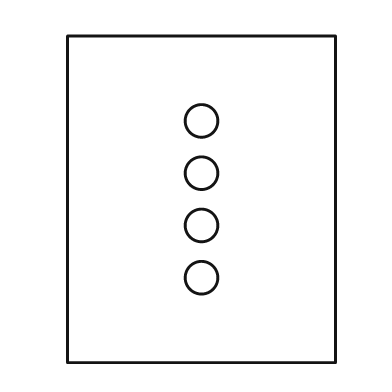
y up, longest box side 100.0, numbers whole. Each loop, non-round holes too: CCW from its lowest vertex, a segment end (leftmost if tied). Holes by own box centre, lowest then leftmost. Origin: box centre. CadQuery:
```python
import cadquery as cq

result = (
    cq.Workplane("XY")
    .moveTo(-41.0, -50.0)
    .lineTo(41.0, -50.0)
    .lineTo(41.0, 50.0)
    .lineTo(-41.0, 50.0)
    .close()
    .moveTo(0.0, -24.0)
    .circle(5.0)
    .moveTo(0.0, -8.0)
    .circle(5.0)
    .moveTo(0.0, 8.0)
    .circle(5.0)
    .moveTo(0.0, 24.0)
    .circle(5.0)
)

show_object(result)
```